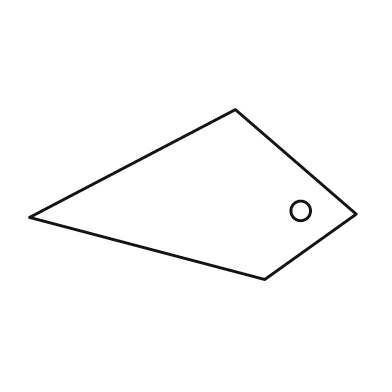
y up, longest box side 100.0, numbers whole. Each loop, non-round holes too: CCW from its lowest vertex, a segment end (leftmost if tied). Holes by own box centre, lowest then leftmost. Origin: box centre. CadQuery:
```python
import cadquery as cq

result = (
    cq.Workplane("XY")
    .moveTo(22.0, -26.0)
    .lineTo(50.0, -6.0)
    .lineTo(13.0, 26.0)
    .lineTo(-50.0, -7.0)
    .close()
    .moveTo(33.0, -5.0)
    .circle(3.0)
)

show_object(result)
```